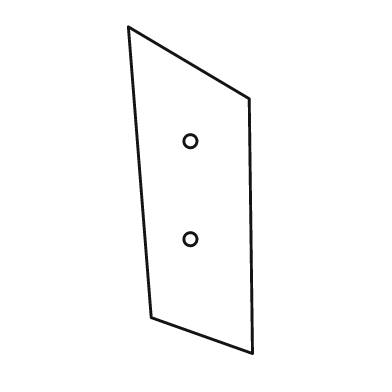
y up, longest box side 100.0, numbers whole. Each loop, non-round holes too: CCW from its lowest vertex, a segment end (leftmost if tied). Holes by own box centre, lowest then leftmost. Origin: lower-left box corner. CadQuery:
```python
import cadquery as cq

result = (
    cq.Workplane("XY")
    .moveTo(38.0, 0.0)
    .lineTo(37.0, 78.0)
    .lineTo(0.0, 100.0)
    .lineTo(7.0, 11.0)
    .close()
    .moveTo(19.0, 35.0)
    .circle(2.0)
    .moveTo(19.0, 65.0)
    .circle(2.0)
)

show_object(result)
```